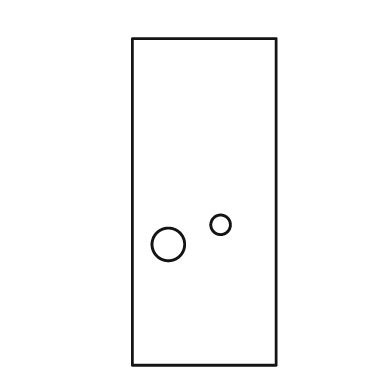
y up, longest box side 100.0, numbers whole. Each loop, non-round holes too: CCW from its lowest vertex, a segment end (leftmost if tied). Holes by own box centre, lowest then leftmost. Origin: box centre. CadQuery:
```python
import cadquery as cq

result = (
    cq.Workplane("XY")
    .moveTo(-22.0, -50.0)
    .lineTo(22.0, -50.0)
    .lineTo(22.0, 50.0)
    .lineTo(-22.0, 50.0)
    .close()
    .moveTo(-11.0, -13.0)
    .circle(5.0)
    .moveTo(5.0, -7.0)
    .circle(3.0)
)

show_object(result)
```